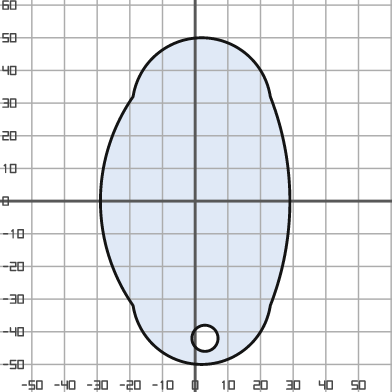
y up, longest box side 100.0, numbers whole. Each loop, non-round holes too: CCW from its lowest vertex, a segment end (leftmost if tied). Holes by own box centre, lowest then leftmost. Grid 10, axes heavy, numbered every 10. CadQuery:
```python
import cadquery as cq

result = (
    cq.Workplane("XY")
    .moveTo(-19.0, -32.0)
    .threePointArc((2.0, -50.0), (23.0, -32.0))
    .threePointArc((29.0, 0.0), (23.0, 32.0))
    .threePointArc((2.0, 50.0), (-19.0, 32.0))
    .threePointArc((-29.0, 0.0), (-19.0, -32.0))
    .close()
    .moveTo(3.0, -42.0)
    .circle(4.0)
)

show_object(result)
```